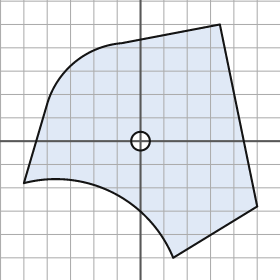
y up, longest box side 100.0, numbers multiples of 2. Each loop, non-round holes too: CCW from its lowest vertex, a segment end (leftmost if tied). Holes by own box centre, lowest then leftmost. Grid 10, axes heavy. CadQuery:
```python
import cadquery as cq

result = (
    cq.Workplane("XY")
    .moveTo(14.0, -50.0)
    .lineTo(50.0, -28.0)
    .lineTo(34.0, 50.0)
    .lineTo(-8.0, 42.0)
    .threePointArc((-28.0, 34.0), (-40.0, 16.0))
    .lineTo(-50.0, -18.0)
    .threePointArc((-12.0, -22.0), (14.0, -50.0))
    .close()
    .moveTo(0.0, 0.0)
    .circle(4.0)
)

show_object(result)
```